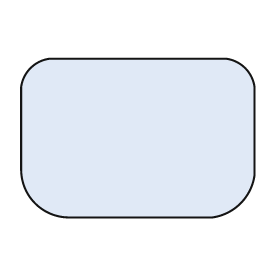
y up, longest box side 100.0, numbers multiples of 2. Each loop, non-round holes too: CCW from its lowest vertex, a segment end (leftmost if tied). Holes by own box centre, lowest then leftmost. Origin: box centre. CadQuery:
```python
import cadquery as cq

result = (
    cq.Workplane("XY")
    .moveTo(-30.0, -34.0)
    .lineTo(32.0, -34.0)
    .threePointArc((44.0, -28.0), (50.0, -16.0))
    .lineTo(50.0, 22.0)
    .threePointArc((46.0, 30.0), (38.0, 34.0))
    .lineTo(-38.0, 34.0)
    .threePointArc((-46.0, 30.0), (-50.0, 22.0))
    .lineTo(-50.0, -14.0)
    .threePointArc((-44.0, -28.0), (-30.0, -34.0))
    .close()
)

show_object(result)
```